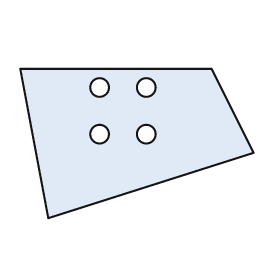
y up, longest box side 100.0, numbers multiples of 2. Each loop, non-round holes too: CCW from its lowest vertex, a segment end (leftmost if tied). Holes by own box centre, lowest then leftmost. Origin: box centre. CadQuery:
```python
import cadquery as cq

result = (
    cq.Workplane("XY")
    .moveTo(-38.0, -32.0)
    .lineTo(50.0, -4.0)
    .lineTo(32.0, 32.0)
    .lineTo(-50.0, 32.0)
    .close()
    .moveTo(-16.0, 4.0)
    .circle(4.0)
    .moveTo(4.0, 4.0)
    .circle(4.0)
    .moveTo(-16.0, 24.0)
    .circle(4.0)
    .moveTo(4.0, 24.0)
    .circle(4.0)
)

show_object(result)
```